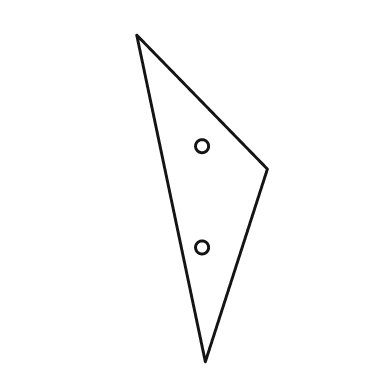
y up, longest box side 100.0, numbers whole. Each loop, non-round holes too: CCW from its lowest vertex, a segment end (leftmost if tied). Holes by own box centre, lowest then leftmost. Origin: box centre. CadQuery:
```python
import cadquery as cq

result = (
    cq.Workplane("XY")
    .moveTo(1.0, -50.0)
    .lineTo(20.0, 9.0)
    .lineTo(-20.0, 50.0)
    .close()
    .moveTo(0.0, -15.0)
    .circle(2.0)
    .moveTo(0.0, 16.0)
    .circle(2.0)
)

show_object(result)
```